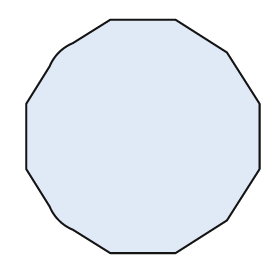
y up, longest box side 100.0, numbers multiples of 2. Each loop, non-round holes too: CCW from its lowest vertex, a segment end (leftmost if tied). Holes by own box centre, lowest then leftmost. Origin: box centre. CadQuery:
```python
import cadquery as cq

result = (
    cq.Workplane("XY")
    .moveTo(-14.0, -50.0)
    .lineTo(14.0, -50.0)
    .lineTo(36.0, -36.0)
    .lineTo(50.0, -14.0)
    .lineTo(50.0, 14.0)
    .lineTo(36.0, 36.0)
    .lineTo(14.0, 50.0)
    .lineTo(-14.0, 50.0)
    .lineTo(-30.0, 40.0)
    .threePointArc((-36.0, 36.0), (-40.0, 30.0))
    .lineTo(-50.0, 14.0)
    .lineTo(-50.0, -14.0)
    .lineTo(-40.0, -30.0)
    .threePointArc((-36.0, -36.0), (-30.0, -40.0))
    .close()
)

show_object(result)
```